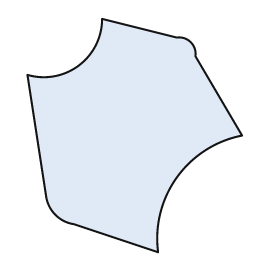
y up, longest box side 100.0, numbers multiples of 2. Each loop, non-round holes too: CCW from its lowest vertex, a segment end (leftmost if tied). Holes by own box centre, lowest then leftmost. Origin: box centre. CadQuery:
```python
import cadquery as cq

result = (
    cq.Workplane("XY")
    .moveTo(10.0, -50.0)
    .threePointArc((18.0, -18.0), (46.0, 0.0))
    .lineTo(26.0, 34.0)
    .threePointArc((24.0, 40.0), (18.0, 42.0))
    .lineTo(-14.0, 50.0)
    .threePointArc((-24.0, 30.0), (-46.0, 26.0))
    .lineTo(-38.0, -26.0)
    .threePointArc((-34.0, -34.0), (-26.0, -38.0))
    .close()
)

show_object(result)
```